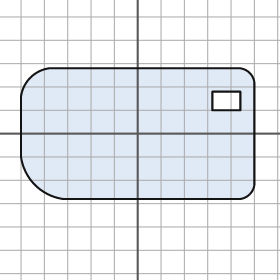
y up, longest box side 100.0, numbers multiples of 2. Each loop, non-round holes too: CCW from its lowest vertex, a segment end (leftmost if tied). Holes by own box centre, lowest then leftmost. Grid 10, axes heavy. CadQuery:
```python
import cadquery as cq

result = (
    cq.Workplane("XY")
    .moveTo(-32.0, -28.0)
    .lineTo(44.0, -28.0)
    .threePointArc((48.0, -26.0), (50.0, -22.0))
    .lineTo(50.0, 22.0)
    .threePointArc((48.0, 26.0), (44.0, 28.0))
    .lineTo(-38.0, 28.0)
    .threePointArc((-46.0, 24.0), (-50.0, 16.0))
    .lineTo(-50.0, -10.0)
    .threePointArc((-44.0, -22.0), (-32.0, -28.0))
    .close()
    .moveTo(32.0, 10.0)
    .lineTo(44.0, 10.0)
    .lineTo(44.0, 18.0)
    .lineTo(32.0, 18.0)
    .close()
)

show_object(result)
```